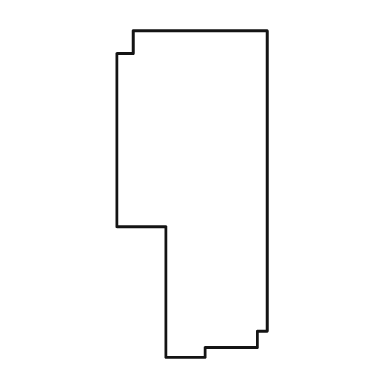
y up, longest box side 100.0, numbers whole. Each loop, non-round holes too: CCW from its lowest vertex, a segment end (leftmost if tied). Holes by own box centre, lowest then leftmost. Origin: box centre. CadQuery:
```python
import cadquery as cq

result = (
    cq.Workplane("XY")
    .moveTo(-8.0, -50.0)
    .lineTo(4.0, -50.0)
    .lineTo(4.0, -47.0)
    .lineTo(20.0, -47.0)
    .lineTo(20.0, -42.0)
    .lineTo(23.0, -42.0)
    .lineTo(23.0, 50.0)
    .lineTo(-18.0, 50.0)
    .lineTo(-18.0, 43.0)
    .lineTo(-23.0, 43.0)
    .lineTo(-23.0, -10.0)
    .lineTo(-8.0, -10.0)
    .close()
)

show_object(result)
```